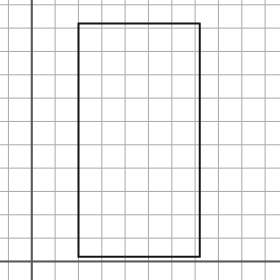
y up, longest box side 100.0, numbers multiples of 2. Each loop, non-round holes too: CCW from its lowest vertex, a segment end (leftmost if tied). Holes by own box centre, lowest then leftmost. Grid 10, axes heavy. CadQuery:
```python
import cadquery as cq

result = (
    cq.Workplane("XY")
    .moveTo(20.0, 2.0)
    .lineTo(72.0, 2.0)
    .lineTo(72.0, 102.0)
    .lineTo(20.0, 102.0)
    .close()
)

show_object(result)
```